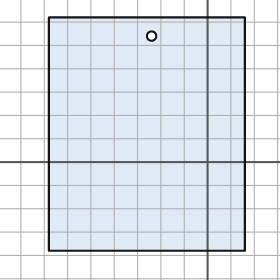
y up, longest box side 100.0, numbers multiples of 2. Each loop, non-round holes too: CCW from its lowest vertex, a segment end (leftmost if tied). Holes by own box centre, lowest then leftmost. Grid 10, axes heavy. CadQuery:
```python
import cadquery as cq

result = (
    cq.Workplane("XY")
    .moveTo(-68.0, -38.0)
    .lineTo(16.0, -38.0)
    .lineTo(16.0, 62.0)
    .lineTo(-68.0, 62.0)
    .close()
    .moveTo(-24.0, 54.0)
    .circle(2.0)
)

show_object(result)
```